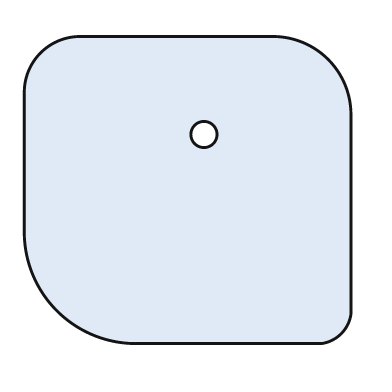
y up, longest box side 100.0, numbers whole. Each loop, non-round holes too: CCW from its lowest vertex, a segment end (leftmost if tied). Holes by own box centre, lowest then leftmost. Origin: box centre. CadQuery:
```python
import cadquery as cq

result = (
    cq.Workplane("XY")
    .moveTo(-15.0, -47.0)
    .lineTo(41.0, -47.0)
    .threePointArc((47.0, -44.0), (50.0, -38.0))
    .lineTo(50.0, 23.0)
    .threePointArc((43.0, 40.0), (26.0, 47.0))
    .lineTo(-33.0, 47.0)
    .threePointArc((-45.0, 42.0), (-50.0, 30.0))
    .lineTo(-50.0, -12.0)
    .threePointArc((-40.0, -37.0), (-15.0, -47.0))
    .close()
    .moveTo(5.0, 17.0)
    .circle(4.0)
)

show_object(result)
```